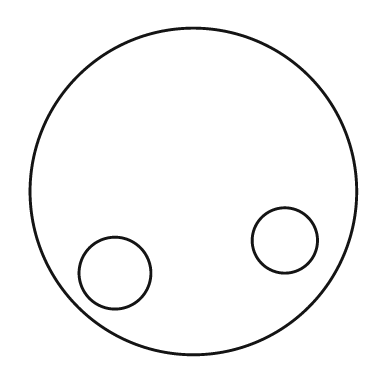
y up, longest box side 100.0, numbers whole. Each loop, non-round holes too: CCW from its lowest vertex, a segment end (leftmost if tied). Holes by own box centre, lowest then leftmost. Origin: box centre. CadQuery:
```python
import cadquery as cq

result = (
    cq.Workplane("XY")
    .moveTo(0.0, 0.0)
    .circle(50.0)
    .moveTo(-24.0, -25.0)
    .circle(11.0)
    .moveTo(28.0, -15.0)
    .circle(10.0)
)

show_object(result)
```